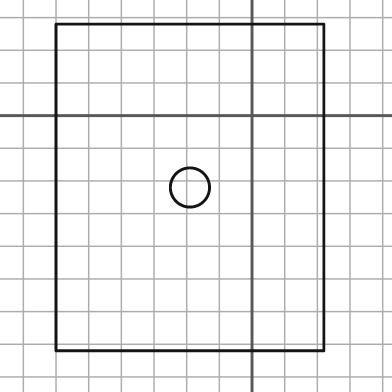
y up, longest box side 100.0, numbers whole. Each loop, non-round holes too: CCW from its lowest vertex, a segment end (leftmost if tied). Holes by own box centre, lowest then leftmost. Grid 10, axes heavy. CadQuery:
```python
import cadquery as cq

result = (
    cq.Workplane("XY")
    .moveTo(-60.0, -72.0)
    .lineTo(22.0, -72.0)
    .lineTo(22.0, 28.0)
    .lineTo(-60.0, 28.0)
    .close()
    .moveTo(-19.0, -22.0)
    .circle(6.0)
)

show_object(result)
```